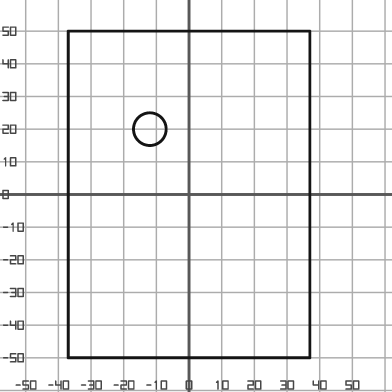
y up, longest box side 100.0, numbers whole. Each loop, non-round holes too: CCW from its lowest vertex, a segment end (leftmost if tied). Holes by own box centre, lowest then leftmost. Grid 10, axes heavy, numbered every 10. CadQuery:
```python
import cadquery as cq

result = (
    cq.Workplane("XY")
    .moveTo(-37.0, -50.0)
    .lineTo(37.0, -50.0)
    .lineTo(37.0, 50.0)
    .lineTo(-37.0, 50.0)
    .close()
    .moveTo(-12.0, 20.0)
    .circle(5.0)
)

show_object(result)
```